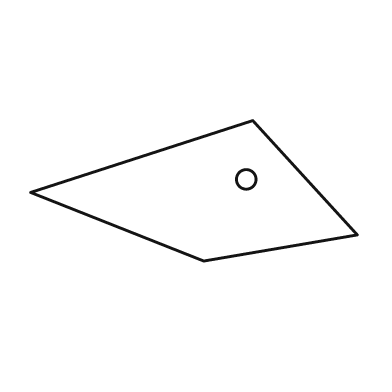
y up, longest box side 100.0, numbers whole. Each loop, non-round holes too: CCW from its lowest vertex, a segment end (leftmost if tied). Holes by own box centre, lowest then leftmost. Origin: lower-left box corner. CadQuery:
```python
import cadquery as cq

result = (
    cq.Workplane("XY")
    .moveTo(53.0, 0.0)
    .lineTo(100.0, 8.0)
    .lineTo(68.0, 43.0)
    .lineTo(0.0, 21.0)
    .close()
    .moveTo(66.0, 25.0)
    .circle(3.0)
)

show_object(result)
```